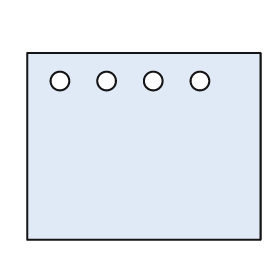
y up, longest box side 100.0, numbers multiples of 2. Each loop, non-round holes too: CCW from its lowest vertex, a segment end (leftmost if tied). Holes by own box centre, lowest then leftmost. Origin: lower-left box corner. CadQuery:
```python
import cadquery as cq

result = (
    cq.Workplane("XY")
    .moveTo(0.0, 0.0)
    .lineTo(100.0, 0.0)
    .lineTo(100.0, 80.0)
    .lineTo(0.0, 80.0)
    .close()
    .moveTo(14.0, 68.0)
    .circle(4.0)
    .moveTo(34.0, 68.0)
    .circle(4.0)
    .moveTo(54.0, 68.0)
    .circle(4.0)
    .moveTo(74.0, 68.0)
    .circle(4.0)
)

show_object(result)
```